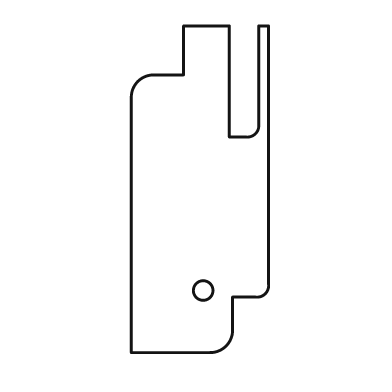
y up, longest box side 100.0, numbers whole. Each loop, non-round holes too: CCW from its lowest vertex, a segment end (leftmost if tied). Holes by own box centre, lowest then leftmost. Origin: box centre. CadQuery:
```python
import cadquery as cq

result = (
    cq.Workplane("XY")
    .moveTo(-21.0, -50.0)
    .lineTo(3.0, -50.0)
    .threePointArc((8.0, -48.0), (10.0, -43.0))
    .lineTo(10.0, -33.0)
    .lineTo(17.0, -33.0)
    .threePointArc((20.0, -32.0), (21.0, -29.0))
    .lineTo(21.0, 50.0)
    .lineTo(18.0, 50.0)
    .lineTo(18.0, 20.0)
    .threePointArc((17.0, 17.0), (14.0, 16.0))
    .lineTo(9.0, 16.0)
    .lineTo(9.0, 50.0)
    .lineTo(-5.0, 50.0)
    .lineTo(-5.0, 35.0)
    .lineTo(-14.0, 35.0)
    .threePointArc((-19.0, 33.0), (-21.0, 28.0))
    .close()
    .moveTo(1.0, -31.0)
    .circle(3.0)
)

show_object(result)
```